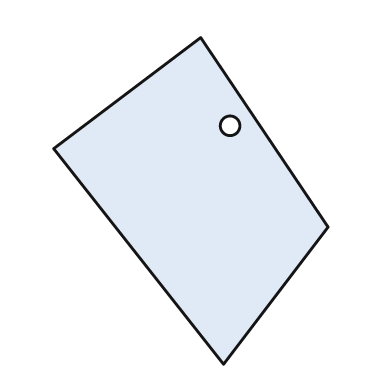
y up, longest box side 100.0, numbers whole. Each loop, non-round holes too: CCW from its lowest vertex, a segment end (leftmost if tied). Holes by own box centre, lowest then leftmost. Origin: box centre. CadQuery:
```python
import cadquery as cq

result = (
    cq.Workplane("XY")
    .moveTo(10.0, -50.0)
    .lineTo(42.0, -8.0)
    .lineTo(3.0, 50.0)
    .lineTo(-42.0, 16.0)
    .close()
    .moveTo(12.0, 23.0)
    .circle(3.0)
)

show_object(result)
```